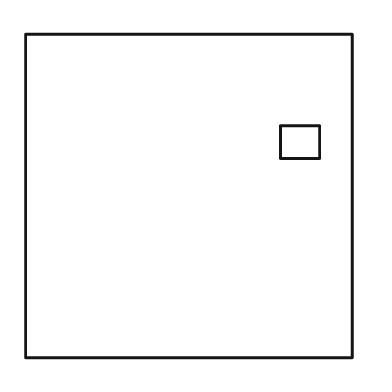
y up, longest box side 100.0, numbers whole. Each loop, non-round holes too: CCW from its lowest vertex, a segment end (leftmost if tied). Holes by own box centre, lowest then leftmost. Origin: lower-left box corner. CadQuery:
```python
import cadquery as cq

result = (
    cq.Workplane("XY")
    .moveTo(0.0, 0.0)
    .lineTo(100.0, 0.0)
    .lineTo(100.0, 99.0)
    .lineTo(0.0, 99.0)
    .close()
    .moveTo(78.0, 61.0)
    .lineTo(90.0, 61.0)
    .lineTo(90.0, 71.0)
    .lineTo(78.0, 71.0)
    .close()
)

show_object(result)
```